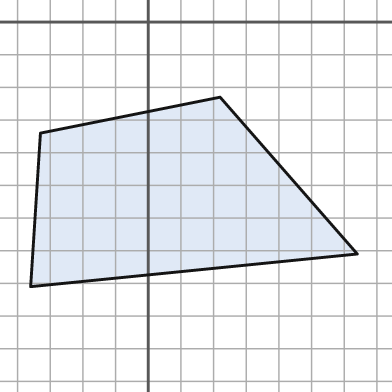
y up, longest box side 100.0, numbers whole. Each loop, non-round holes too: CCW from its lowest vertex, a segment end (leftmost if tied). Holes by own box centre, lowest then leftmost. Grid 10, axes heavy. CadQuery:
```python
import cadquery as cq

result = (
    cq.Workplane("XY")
    .moveTo(-36.0, -81.0)
    .lineTo(64.0, -71.0)
    .lineTo(22.0, -23.0)
    .lineTo(-33.0, -34.0)
    .close()
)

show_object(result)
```